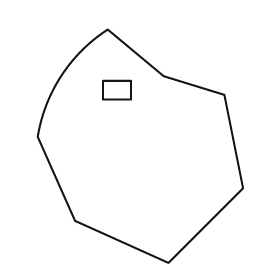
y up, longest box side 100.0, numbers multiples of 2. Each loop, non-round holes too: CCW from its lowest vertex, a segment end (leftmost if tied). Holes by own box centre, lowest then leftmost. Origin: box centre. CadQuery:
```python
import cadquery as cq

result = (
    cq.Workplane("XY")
    .moveTo(12.0, -50.0)
    .lineTo(44.0, -18.0)
    .lineTo(36.0, 22.0)
    .lineTo(10.0, 30.0)
    .lineTo(-14.0, 50.0)
    .threePointArc((-34.0, 30.0), (-44.0, 4.0))
    .lineTo(-28.0, -32.0)
    .close()
    .moveTo(-16.0, 20.0)
    .lineTo(-4.0, 20.0)
    .lineTo(-4.0, 28.0)
    .lineTo(-16.0, 28.0)
    .close()
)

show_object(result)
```